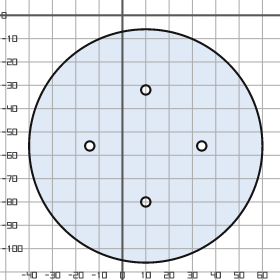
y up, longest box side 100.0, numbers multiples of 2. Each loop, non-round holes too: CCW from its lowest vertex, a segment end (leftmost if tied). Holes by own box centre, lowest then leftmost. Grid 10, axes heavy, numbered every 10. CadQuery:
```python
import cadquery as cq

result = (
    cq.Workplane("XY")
    .moveTo(10.0, -56.0)
    .circle(50.0)
    .moveTo(10.0, -80.0)
    .circle(2.0)
    .moveTo(-14.0, -56.0)
    .circle(2.0)
    .moveTo(34.0, -56.0)
    .circle(2.0)
    .moveTo(10.0, -32.0)
    .circle(2.0)
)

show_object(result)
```